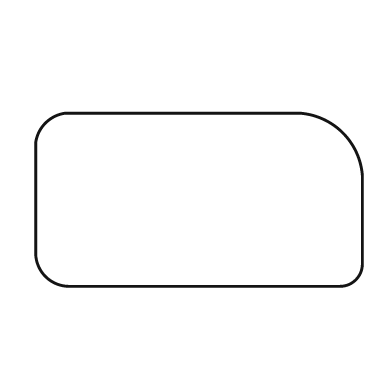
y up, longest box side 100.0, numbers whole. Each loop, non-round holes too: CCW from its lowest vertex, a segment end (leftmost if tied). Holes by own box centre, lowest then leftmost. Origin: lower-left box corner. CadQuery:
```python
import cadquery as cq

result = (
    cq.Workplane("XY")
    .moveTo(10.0, 0.0)
    .lineTo(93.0, 0.0)
    .threePointArc((98.0, 2.0), (100.0, 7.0))
    .lineTo(100.0, 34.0)
    .threePointArc((94.0, 47.0), (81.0, 53.0))
    .lineTo(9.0, 53.0)
    .threePointArc((3.0, 50.0), (0.0, 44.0))
    .lineTo(0.0, 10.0)
    .threePointArc((3.0, 3.0), (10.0, 0.0))
    .close()
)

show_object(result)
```